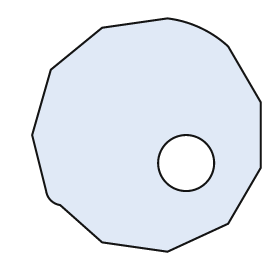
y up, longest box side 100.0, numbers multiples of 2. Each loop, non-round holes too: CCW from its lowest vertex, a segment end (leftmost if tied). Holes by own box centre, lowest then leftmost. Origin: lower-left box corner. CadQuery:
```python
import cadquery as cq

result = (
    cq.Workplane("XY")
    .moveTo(58.0, 0.0)
    .lineTo(84.0, 12.0)
    .lineTo(98.0, 36.0)
    .lineTo(98.0, 64.0)
    .lineTo(84.0, 88.0)
    .threePointArc((72.0, 96.0), (58.0, 100.0))
    .lineTo(30.0, 96.0)
    .lineTo(8.0, 78.0)
    .lineTo(0.0, 50.0)
    .lineTo(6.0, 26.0)
    .threePointArc((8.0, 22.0), (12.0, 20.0))
    .lineTo(30.0, 4.0)
    .close()
    .moveTo(66.0, 38.0)
    .circle(12.0)
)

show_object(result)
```